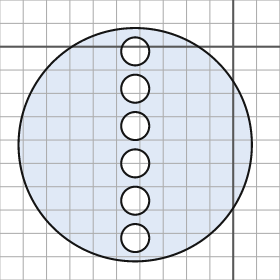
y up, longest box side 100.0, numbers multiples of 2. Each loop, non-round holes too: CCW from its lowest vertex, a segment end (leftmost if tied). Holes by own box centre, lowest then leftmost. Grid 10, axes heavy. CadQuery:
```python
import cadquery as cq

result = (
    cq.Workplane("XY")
    .moveTo(-42.0, -42.0)
    .circle(50.0)
    .moveTo(-42.0, -82.0)
    .circle(6.0)
    .moveTo(-42.0, -66.0)
    .circle(6.0)
    .moveTo(-42.0, -50.0)
    .circle(6.0)
    .moveTo(-42.0, -34.0)
    .circle(6.0)
    .moveTo(-42.0, -18.0)
    .circle(6.0)
    .moveTo(-42.0, -2.0)
    .circle(6.0)
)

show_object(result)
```